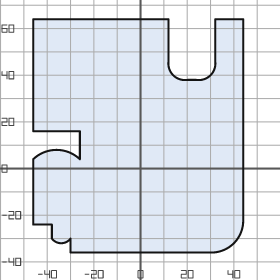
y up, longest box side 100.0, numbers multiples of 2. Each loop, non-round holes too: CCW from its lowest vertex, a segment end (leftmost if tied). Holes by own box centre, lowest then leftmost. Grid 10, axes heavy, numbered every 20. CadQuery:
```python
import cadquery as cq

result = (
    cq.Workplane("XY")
    .moveTo(-30.0, -36.0)
    .lineTo(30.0, -36.0)
    .threePointArc((40.0, -32.0), (44.0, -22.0))
    .lineTo(44.0, 64.0)
    .lineTo(32.0, 64.0)
    .lineTo(32.0, 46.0)
    .threePointArc((30.0, 40.0), (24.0, 38.0))
    .lineTo(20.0, 38.0)
    .threePointArc((14.0, 40.0), (12.0, 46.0))
    .lineTo(12.0, 64.0)
    .lineTo(-46.0, 64.0)
    .lineTo(-46.0, 16.0)
    .lineTo(-26.0, 16.0)
    .lineTo(-26.0, 4.0)
    .threePointArc((-36.0, 8.0), (-46.0, 4.0))
    .lineTo(-46.0, -24.0)
    .lineTo(-38.0, -24.0)
    .lineTo(-38.0, -30.0)
    .threePointArc((-34.0, -32.0), (-30.0, -30.0))
    .close()
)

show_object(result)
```